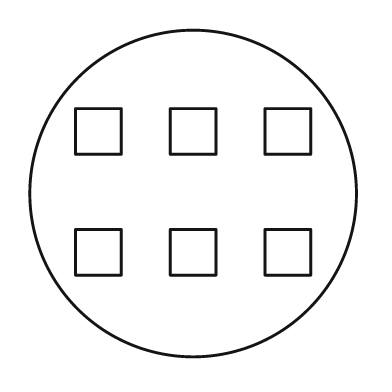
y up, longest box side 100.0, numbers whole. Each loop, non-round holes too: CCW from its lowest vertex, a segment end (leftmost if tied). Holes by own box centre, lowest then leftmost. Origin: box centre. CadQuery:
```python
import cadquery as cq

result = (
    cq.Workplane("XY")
    .moveTo(0.0, 0.0)
    .circle(50.0)
    .moveTo(-36.0, -25.0)
    .lineTo(-22.0, -25.0)
    .lineTo(-22.0, -11.0)
    .lineTo(-36.0, -11.0)
    .close()
    .moveTo(-7.0, -25.0)
    .lineTo(7.0, -25.0)
    .lineTo(7.0, -11.0)
    .lineTo(-7.0, -11.0)
    .close()
    .moveTo(22.0, -25.0)
    .lineTo(36.0, -25.0)
    .lineTo(36.0, -11.0)
    .lineTo(22.0, -11.0)
    .close()
    .moveTo(-36.0, 12.0)
    .lineTo(-22.0, 12.0)
    .lineTo(-22.0, 26.0)
    .lineTo(-36.0, 26.0)
    .close()
    .moveTo(-7.0, 12.0)
    .lineTo(7.0, 12.0)
    .lineTo(7.0, 26.0)
    .lineTo(-7.0, 26.0)
    .close()
    .moveTo(22.0, 12.0)
    .lineTo(36.0, 12.0)
    .lineTo(36.0, 26.0)
    .lineTo(22.0, 26.0)
    .close()
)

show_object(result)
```